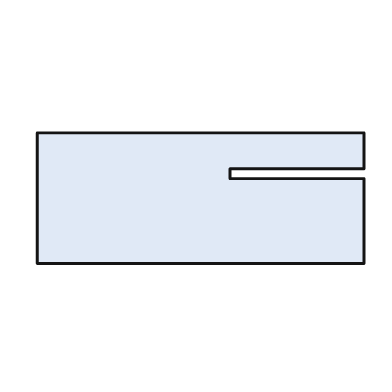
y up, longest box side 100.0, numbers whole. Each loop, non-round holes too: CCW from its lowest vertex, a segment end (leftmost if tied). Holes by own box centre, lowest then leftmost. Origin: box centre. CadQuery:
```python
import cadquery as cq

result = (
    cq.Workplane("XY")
    .moveTo(-50.0, -20.0)
    .lineTo(50.0, -20.0)
    .lineTo(50.0, 6.0)
    .lineTo(9.0, 6.0)
    .lineTo(9.0, 9.0)
    .lineTo(50.0, 9.0)
    .lineTo(50.0, 20.0)
    .lineTo(-50.0, 20.0)
    .close()
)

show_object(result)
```